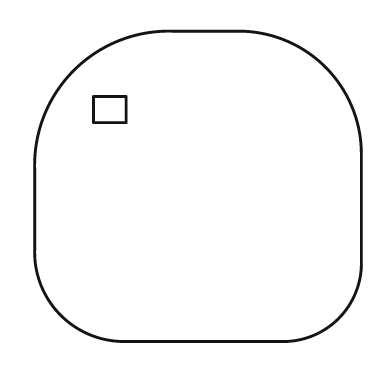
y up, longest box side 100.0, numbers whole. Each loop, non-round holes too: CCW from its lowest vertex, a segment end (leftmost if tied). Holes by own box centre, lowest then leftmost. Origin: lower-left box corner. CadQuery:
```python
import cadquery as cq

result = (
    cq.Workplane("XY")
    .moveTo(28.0, 0.0)
    .lineTo(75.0, 0.0)
    .threePointArc((93.0, 7.0), (100.0, 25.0))
    .lineTo(100.0, 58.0)
    .threePointArc((89.0, 84.0), (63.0, 95.0))
    .lineTo(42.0, 95.0)
    .threePointArc((12.0, 83.0), (0.0, 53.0))
    .lineTo(0.0, 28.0)
    .threePointArc((8.0, 8.0), (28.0, 0.0))
    .close()
    .moveTo(18.0, 67.0)
    .lineTo(28.0, 67.0)
    .lineTo(28.0, 75.0)
    .lineTo(18.0, 75.0)
    .close()
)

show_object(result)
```